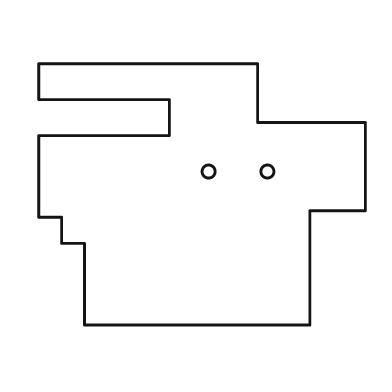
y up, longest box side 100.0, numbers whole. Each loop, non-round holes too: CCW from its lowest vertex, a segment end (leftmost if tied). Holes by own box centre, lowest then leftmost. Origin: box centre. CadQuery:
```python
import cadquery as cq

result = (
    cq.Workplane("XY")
    .moveTo(-36.0, -40.0)
    .lineTo(33.0, -40.0)
    .lineTo(33.0, -5.0)
    .lineTo(50.0, -5.0)
    .lineTo(50.0, 22.0)
    .lineTo(17.0, 22.0)
    .lineTo(17.0, 40.0)
    .lineTo(-50.0, 40.0)
    .lineTo(-50.0, 29.0)
    .lineTo(-10.0, 29.0)
    .lineTo(-10.0, 18.0)
    .lineTo(-50.0, 18.0)
    .lineTo(-50.0, -7.0)
    .lineTo(-43.0, -7.0)
    .lineTo(-43.0, -15.0)
    .lineTo(-36.0, -15.0)
    .close()
    .moveTo(2.0, 7.0)
    .circle(2.0)
    .moveTo(20.0, 7.0)
    .circle(2.0)
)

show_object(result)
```